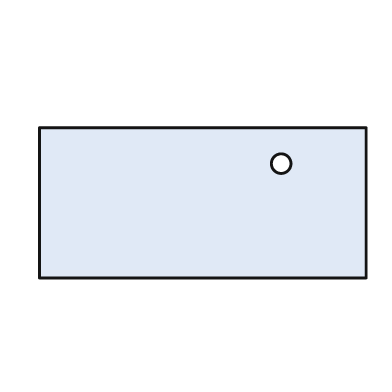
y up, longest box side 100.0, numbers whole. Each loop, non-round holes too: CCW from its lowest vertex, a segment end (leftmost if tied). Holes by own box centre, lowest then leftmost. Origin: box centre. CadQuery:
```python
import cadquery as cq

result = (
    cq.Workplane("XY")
    .moveTo(-50.0, -23.0)
    .lineTo(50.0, -23.0)
    .lineTo(50.0, 23.0)
    .lineTo(-50.0, 23.0)
    .close()
    .moveTo(24.0, 12.0)
    .circle(3.0)
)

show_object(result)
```